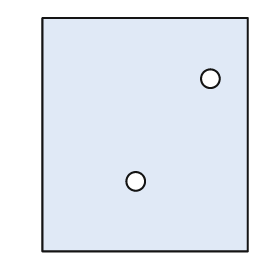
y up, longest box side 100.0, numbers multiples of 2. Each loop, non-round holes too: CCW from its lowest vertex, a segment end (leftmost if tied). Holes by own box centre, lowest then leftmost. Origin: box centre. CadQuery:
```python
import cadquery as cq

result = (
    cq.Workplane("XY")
    .moveTo(-44.0, -50.0)
    .lineTo(44.0, -50.0)
    .lineTo(44.0, 50.0)
    .lineTo(-44.0, 50.0)
    .close()
    .moveTo(-4.0, -20.0)
    .circle(4.0)
    .moveTo(28.0, 24.0)
    .circle(4.0)
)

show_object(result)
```